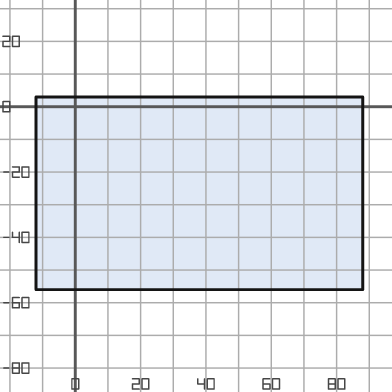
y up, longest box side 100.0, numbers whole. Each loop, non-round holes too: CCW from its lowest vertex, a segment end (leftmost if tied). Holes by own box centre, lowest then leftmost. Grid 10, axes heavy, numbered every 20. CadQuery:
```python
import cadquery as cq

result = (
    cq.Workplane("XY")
    .moveTo(-12.0, -56.0)
    .lineTo(88.0, -56.0)
    .lineTo(88.0, 3.0)
    .lineTo(-12.0, 3.0)
    .close()
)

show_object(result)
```